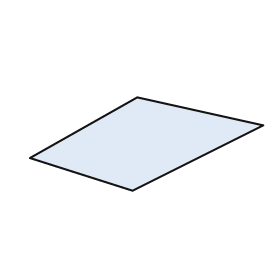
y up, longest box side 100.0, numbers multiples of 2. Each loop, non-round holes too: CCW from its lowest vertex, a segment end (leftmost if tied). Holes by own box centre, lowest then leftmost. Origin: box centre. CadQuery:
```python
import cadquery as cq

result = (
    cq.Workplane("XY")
    .moveTo(-6.0, -20.0)
    .lineTo(50.0, 8.0)
    .lineTo(-4.0, 20.0)
    .lineTo(-50.0, -6.0)
    .close()
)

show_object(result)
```